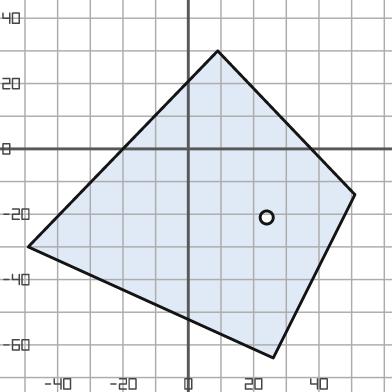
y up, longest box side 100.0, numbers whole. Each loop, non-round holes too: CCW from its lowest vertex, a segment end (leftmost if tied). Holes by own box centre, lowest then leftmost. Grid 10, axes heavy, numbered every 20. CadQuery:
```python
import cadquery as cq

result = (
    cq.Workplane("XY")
    .moveTo(26.0, -64.0)
    .lineTo(51.0, -14.0)
    .lineTo(9.0, 30.0)
    .lineTo(-49.0, -30.0)
    .close()
    .moveTo(24.0, -21.0)
    .circle(2.0)
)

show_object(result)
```